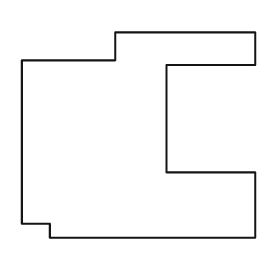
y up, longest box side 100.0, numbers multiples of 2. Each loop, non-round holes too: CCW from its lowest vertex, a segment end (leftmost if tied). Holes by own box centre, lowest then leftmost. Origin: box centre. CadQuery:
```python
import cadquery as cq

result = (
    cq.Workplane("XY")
    .moveTo(-38.0, -44.0)
    .lineTo(50.0, -44.0)
    .lineTo(50.0, -16.0)
    .lineTo(12.0, -16.0)
    .lineTo(12.0, 30.0)
    .lineTo(50.0, 30.0)
    .lineTo(50.0, 44.0)
    .lineTo(-10.0, 44.0)
    .lineTo(-10.0, 32.0)
    .lineTo(-50.0, 32.0)
    .lineTo(-50.0, -38.0)
    .lineTo(-38.0, -38.0)
    .close()
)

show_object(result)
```